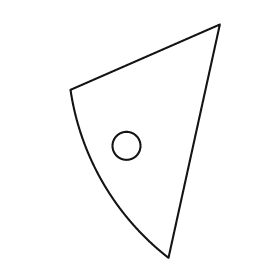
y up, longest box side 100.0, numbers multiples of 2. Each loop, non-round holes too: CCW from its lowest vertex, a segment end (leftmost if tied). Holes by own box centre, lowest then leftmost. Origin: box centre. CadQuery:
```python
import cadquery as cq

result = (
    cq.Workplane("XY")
    .moveTo(10.0, -50.0)
    .lineTo(32.0, 50.0)
    .lineTo(-32.0, 22.0)
    .threePointArc((-18.0, -18.0), (10.0, -50.0))
    .close()
    .moveTo(-8.0, -2.0)
    .circle(6.0)
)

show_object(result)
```